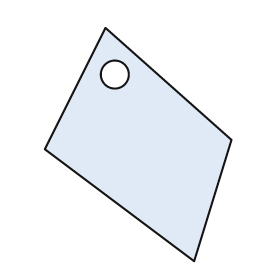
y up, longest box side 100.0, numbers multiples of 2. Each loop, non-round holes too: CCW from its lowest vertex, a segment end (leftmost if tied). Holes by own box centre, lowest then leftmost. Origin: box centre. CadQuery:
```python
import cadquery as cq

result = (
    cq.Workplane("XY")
    .moveTo(24.0, -50.0)
    .lineTo(40.0, 2.0)
    .lineTo(-14.0, 50.0)
    .lineTo(-40.0, -2.0)
    .close()
    .moveTo(-10.0, 30.0)
    .circle(6.0)
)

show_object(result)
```